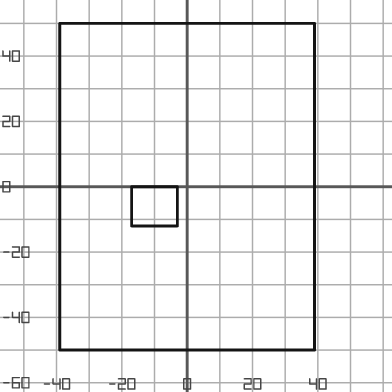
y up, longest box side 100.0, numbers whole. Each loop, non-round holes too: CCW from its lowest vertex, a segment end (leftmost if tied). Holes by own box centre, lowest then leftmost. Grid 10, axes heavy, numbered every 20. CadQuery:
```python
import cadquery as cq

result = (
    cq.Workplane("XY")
    .moveTo(-39.0, -50.0)
    .lineTo(39.0, -50.0)
    .lineTo(39.0, 50.0)
    .lineTo(-39.0, 50.0)
    .close()
    .moveTo(-17.0, -12.0)
    .lineTo(-3.0, -12.0)
    .lineTo(-3.0, 0.0)
    .lineTo(-17.0, 0.0)
    .close()
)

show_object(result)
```